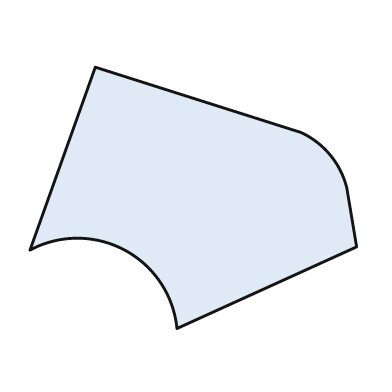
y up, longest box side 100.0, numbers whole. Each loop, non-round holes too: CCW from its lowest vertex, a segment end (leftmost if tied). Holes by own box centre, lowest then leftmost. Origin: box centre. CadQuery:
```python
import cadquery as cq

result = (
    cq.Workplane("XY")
    .moveTo(-5.0, -40.0)
    .lineTo(50.0, -15.0)
    .lineTo(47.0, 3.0)
    .threePointArc((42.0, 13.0), (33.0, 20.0))
    .lineTo(-30.0, 40.0)
    .lineTo(-50.0, -16.0)
    .threePointArc((-21.0, -16.0), (-5.0, -40.0))
    .close()
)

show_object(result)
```